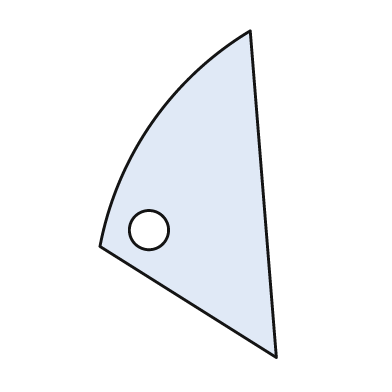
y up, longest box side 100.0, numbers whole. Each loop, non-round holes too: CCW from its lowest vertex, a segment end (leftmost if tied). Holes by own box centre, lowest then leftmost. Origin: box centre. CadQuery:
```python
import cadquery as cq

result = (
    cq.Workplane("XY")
    .moveTo(27.0, -50.0)
    .lineTo(19.0, 50.0)
    .threePointArc((-11.0, 22.0), (-27.0, -16.0))
    .close()
    .moveTo(-12.0, -11.0)
    .circle(6.0)
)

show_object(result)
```